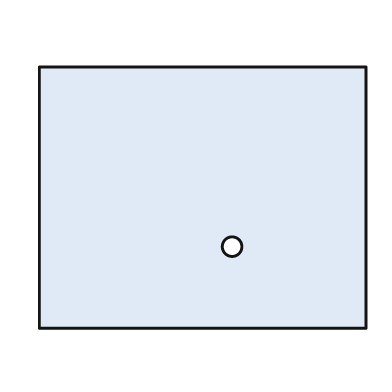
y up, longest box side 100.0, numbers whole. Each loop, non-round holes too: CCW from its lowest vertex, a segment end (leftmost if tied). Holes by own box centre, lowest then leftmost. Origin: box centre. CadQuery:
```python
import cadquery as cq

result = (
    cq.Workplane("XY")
    .moveTo(-50.0, -40.0)
    .lineTo(50.0, -40.0)
    .lineTo(50.0, 40.0)
    .lineTo(-50.0, 40.0)
    .close()
    .moveTo(9.0, -15.0)
    .circle(3.0)
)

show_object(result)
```